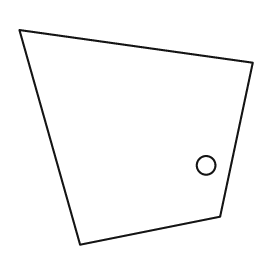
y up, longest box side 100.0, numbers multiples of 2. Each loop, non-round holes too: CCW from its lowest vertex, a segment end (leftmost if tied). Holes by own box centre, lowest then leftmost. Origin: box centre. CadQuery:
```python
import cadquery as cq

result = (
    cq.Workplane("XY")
    .moveTo(-24.0, -46.0)
    .lineTo(36.0, -34.0)
    .lineTo(50.0, 32.0)
    .lineTo(-50.0, 46.0)
    .close()
    .moveTo(30.0, -12.0)
    .circle(4.0)
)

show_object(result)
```